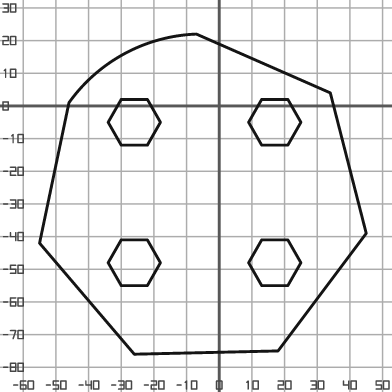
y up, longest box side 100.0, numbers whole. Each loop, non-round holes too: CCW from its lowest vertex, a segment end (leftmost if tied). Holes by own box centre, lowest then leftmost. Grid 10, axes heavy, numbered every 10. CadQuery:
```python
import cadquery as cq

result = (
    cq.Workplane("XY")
    .moveTo(-26.0, -76.0)
    .lineTo(18.0, -75.0)
    .lineTo(45.0, -39.0)
    .lineTo(34.0, 4.0)
    .lineTo(-7.0, 22.0)
    .threePointArc((-29.0, 16.0), (-46.0, 1.0))
    .lineTo(-55.0, -42.0)
    .close()
    .moveTo(-30.0, -55.0)
    .lineTo(-22.0, -55.0)
    .lineTo(-18.0, -48.0)
    .lineTo(-22.0, -41.0)
    .lineTo(-30.0, -41.0)
    .lineTo(-34.0, -48.0)
    .close()
    .moveTo(13.0, -55.0)
    .lineTo(21.0, -55.0)
    .lineTo(25.0, -48.0)
    .lineTo(21.0, -41.0)
    .lineTo(13.0, -41.0)
    .lineTo(9.0, -48.0)
    .close()
    .moveTo(-30.0, -12.0)
    .lineTo(-22.0, -12.0)
    .lineTo(-18.0, -5.0)
    .lineTo(-22.0, 2.0)
    .lineTo(-30.0, 2.0)
    .lineTo(-34.0, -5.0)
    .close()
    .moveTo(13.0, -12.0)
    .lineTo(21.0, -12.0)
    .lineTo(25.0, -5.0)
    .lineTo(21.0, 2.0)
    .lineTo(13.0, 2.0)
    .lineTo(9.0, -5.0)
    .close()
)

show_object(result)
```